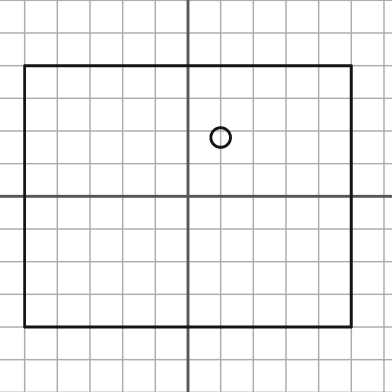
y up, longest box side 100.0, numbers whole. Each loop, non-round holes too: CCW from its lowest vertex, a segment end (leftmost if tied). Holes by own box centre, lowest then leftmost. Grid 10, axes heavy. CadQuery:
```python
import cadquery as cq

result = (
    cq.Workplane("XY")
    .moveTo(-50.0, -40.0)
    .lineTo(50.0, -40.0)
    .lineTo(50.0, 40.0)
    .lineTo(-50.0, 40.0)
    .close()
    .moveTo(10.0, 18.0)
    .circle(3.0)
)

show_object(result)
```